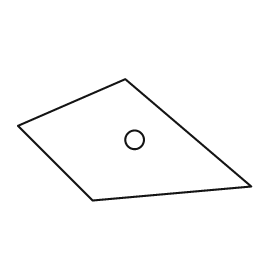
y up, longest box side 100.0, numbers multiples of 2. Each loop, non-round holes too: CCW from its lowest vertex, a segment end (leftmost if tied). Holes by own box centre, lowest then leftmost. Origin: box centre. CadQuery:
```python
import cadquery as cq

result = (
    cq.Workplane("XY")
    .moveTo(-18.0, -26.0)
    .lineTo(50.0, -20.0)
    .lineTo(-4.0, 26.0)
    .lineTo(-50.0, 6.0)
    .close()
    .moveTo(0.0, 0.0)
    .circle(4.0)
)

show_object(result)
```